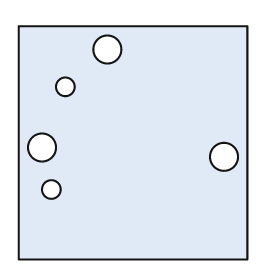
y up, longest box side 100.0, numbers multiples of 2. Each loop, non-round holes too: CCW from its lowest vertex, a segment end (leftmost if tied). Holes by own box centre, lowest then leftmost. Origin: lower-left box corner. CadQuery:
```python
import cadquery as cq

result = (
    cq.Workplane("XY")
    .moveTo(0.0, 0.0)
    .lineTo(98.0, 0.0)
    .lineTo(98.0, 100.0)
    .lineTo(0.0, 100.0)
    .close()
    .moveTo(14.0, 30.0)
    .circle(4.0)
    .moveTo(88.0, 44.0)
    .circle(6.0)
    .moveTo(10.0, 48.0)
    .circle(6.0)
    .moveTo(20.0, 74.0)
    .circle(4.0)
    .moveTo(38.0, 90.0)
    .circle(6.0)
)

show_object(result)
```